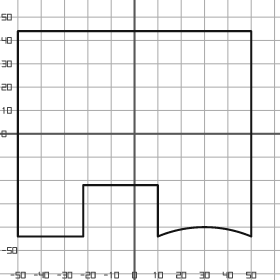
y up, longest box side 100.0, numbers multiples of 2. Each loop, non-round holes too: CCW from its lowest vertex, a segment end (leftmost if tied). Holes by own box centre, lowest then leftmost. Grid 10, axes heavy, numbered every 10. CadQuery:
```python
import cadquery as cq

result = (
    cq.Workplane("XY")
    .moveTo(-50.0, -44.0)
    .lineTo(-22.0, -44.0)
    .lineTo(-22.0, -22.0)
    .lineTo(10.0, -22.0)
    .lineTo(10.0, -44.0)
    .threePointArc((30.0, -40.0), (50.0, -44.0))
    .lineTo(50.0, 44.0)
    .lineTo(-50.0, 44.0)
    .close()
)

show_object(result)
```